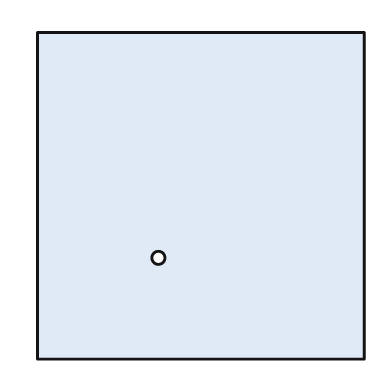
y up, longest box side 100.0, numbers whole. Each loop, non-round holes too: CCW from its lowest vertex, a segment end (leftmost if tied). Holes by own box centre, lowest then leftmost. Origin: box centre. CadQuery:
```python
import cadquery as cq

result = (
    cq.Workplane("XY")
    .moveTo(-50.0, -50.0)
    .lineTo(50.0, -50.0)
    .lineTo(50.0, 50.0)
    .lineTo(-50.0, 50.0)
    .close()
    .moveTo(-13.0, -19.0)
    .circle(2.0)
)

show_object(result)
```